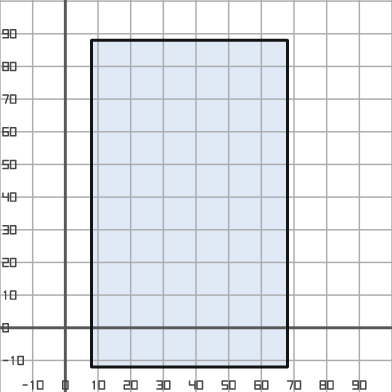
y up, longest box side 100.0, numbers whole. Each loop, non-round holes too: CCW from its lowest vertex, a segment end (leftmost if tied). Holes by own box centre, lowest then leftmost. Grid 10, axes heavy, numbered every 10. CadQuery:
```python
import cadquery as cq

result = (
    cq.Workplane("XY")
    .moveTo(8.0, -12.0)
    .lineTo(68.0, -12.0)
    .lineTo(68.0, 88.0)
    .lineTo(8.0, 88.0)
    .close()
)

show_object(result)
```